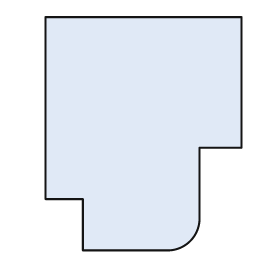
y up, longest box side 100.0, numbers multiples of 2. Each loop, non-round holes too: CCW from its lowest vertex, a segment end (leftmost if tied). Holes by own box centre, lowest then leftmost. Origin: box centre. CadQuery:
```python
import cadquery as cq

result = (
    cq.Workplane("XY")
    .moveTo(-26.0, -50.0)
    .lineTo(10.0, -50.0)
    .threePointArc((20.0, -46.0), (24.0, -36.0))
    .lineTo(24.0, -6.0)
    .lineTo(42.0, -6.0)
    .lineTo(42.0, 50.0)
    .lineTo(-42.0, 50.0)
    .lineTo(-42.0, -28.0)
    .lineTo(-26.0, -28.0)
    .close()
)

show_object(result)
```